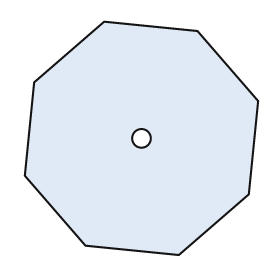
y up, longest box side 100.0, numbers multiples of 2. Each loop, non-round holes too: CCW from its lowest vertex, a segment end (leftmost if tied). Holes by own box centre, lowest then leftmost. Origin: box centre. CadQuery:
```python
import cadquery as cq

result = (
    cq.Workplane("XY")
    .moveTo(16.0, -50.0)
    .lineTo(46.0, -24.0)
    .lineTo(50.0, 16.0)
    .lineTo(24.0, 46.0)
    .lineTo(-16.0, 50.0)
    .lineTo(-46.0, 24.0)
    .lineTo(-50.0, -16.0)
    .lineTo(-24.0, -46.0)
    .close()
    .moveTo(0.0, 0.0)
    .circle(4.0)
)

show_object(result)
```